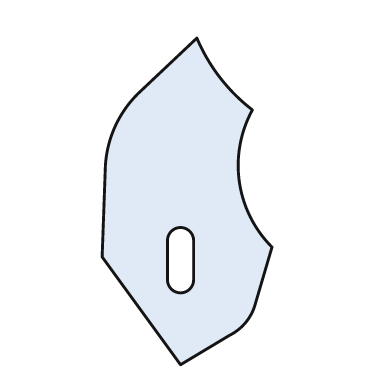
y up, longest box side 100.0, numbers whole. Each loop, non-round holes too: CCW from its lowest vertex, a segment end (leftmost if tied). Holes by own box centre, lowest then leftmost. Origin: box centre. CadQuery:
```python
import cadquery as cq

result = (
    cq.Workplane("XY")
    .moveTo(-2.0, -50.0)
    .lineTo(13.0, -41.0)
    .threePointArc((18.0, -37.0), (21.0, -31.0))
    .lineTo(26.0, -14.0)
    .threePointArc((16.0, 6.0), (20.0, 28.0))
    .threePointArc((10.0, 38.0), (3.0, 50.0))
    .lineTo(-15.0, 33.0)
    .threePointArc((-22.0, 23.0), (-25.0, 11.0))
    .lineTo(-26.0, -17.0)
    .close()
    .moveTo(-6.0, -24.0)
    .threePointArc((-2.0, -28.0), (2.0, -24.0))
    .lineTo(2.0, -12.0)
    .threePointArc((-2.0, -8.0), (-6.0, -12.0))
    .close()
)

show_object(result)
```